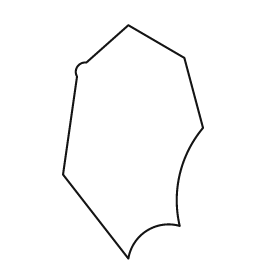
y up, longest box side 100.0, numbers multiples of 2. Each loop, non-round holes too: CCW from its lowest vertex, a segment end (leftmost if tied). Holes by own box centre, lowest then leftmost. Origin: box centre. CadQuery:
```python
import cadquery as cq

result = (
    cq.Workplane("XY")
    .moveTo(-2.0, -50.0)
    .threePointArc((6.0, -38.0), (20.0, -36.0))
    .threePointArc((20.0, -14.0), (30.0, 6.0))
    .lineTo(22.0, 36.0)
    .lineTo(-2.0, 50.0)
    .lineTo(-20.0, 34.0)
    .threePointArc((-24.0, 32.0), (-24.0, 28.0))
    .lineTo(-30.0, -14.0)
    .close()
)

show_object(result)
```